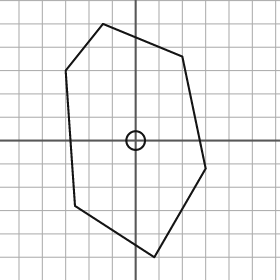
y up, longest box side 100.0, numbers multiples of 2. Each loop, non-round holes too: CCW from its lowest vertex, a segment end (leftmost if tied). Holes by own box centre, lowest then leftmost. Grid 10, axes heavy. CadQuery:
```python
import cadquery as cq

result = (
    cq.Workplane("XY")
    .moveTo(8.0, -50.0)
    .lineTo(30.0, -12.0)
    .lineTo(20.0, 36.0)
    .lineTo(-14.0, 50.0)
    .lineTo(-30.0, 30.0)
    .lineTo(-26.0, -28.0)
    .close()
    .moveTo(0.0, 0.0)
    .circle(4.0)
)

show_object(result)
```